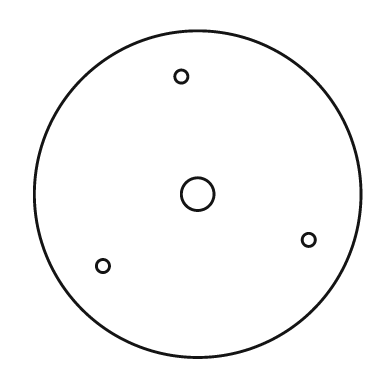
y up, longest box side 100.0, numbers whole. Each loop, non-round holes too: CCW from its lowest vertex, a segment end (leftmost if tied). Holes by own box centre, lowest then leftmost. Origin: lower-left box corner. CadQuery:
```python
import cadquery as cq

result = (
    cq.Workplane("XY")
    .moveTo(50.0, 50.0)
    .circle(50.0)
    .moveTo(21.0, 28.0)
    .circle(2.0)
    .moveTo(84.0, 36.0)
    .circle(2.0)
    .moveTo(50.0, 50.0)
    .circle(5.0)
    .moveTo(45.0, 86.0)
    .circle(2.0)
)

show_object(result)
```